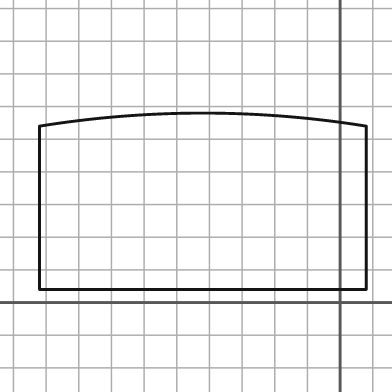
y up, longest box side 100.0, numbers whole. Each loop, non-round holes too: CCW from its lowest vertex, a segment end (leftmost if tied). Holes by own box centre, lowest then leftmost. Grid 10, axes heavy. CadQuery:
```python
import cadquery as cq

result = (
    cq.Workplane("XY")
    .moveTo(-92.0, 4.0)
    .lineTo(8.0, 4.0)
    .lineTo(8.0, 54.0)
    .threePointArc((-42.0, 58.0), (-92.0, 54.0))
    .close()
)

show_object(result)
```